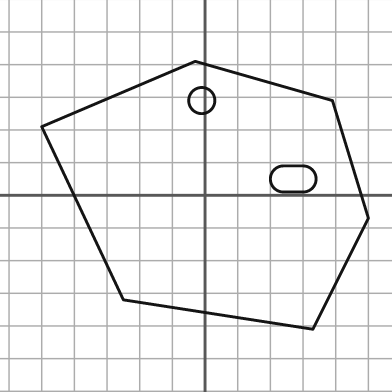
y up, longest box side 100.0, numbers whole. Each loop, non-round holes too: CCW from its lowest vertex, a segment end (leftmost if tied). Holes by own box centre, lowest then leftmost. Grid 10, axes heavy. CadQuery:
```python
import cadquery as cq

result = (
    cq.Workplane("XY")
    .moveTo(33.0, -41.0)
    .lineTo(50.0, -7.0)
    .lineTo(39.0, 29.0)
    .lineTo(-3.0, 41.0)
    .lineTo(-50.0, 21.0)
    .lineTo(-25.0, -32.0)
    .close()
    .moveTo(24.0, 1.0)
    .lineTo(30.0, 1.0)
    .threePointArc((34.0, 5.0), (30.0, 9.0))
    .lineTo(24.0, 9.0)
    .threePointArc((20.0, 5.0), (24.0, 1.0))
    .close()
    .moveTo(-1.0, 29.0)
    .circle(4.0)
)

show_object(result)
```